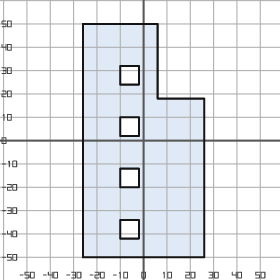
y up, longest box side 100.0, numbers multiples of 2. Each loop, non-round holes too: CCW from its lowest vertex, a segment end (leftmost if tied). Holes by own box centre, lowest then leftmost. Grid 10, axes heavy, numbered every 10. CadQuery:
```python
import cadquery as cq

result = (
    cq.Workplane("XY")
    .moveTo(-26.0, -50.0)
    .lineTo(26.0, -50.0)
    .lineTo(26.0, 18.0)
    .lineTo(6.0, 18.0)
    .lineTo(6.0, 50.0)
    .lineTo(-26.0, 50.0)
    .close()
    .moveTo(-10.0, -42.0)
    .lineTo(-2.0, -42.0)
    .lineTo(-2.0, -34.0)
    .lineTo(-10.0, -34.0)
    .close()
    .moveTo(-10.0, -20.0)
    .lineTo(-2.0, -20.0)
    .lineTo(-2.0, -12.0)
    .lineTo(-10.0, -12.0)
    .close()
    .moveTo(-10.0, 2.0)
    .lineTo(-2.0, 2.0)
    .lineTo(-2.0, 10.0)
    .lineTo(-10.0, 10.0)
    .close()
    .moveTo(-10.0, 24.0)
    .lineTo(-2.0, 24.0)
    .lineTo(-2.0, 32.0)
    .lineTo(-10.0, 32.0)
    .close()
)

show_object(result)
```